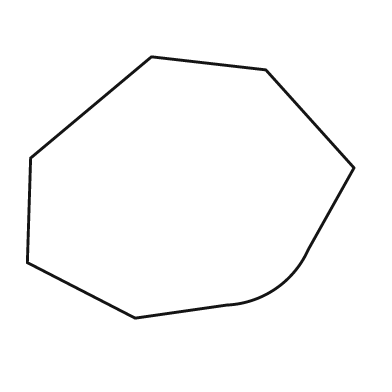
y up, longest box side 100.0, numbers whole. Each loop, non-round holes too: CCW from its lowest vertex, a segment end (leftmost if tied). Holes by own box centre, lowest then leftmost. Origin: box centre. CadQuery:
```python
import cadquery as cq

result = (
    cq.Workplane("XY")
    .moveTo(-17.0, -40.0)
    .lineTo(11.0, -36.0)
    .threePointArc((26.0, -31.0), (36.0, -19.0))
    .lineTo(50.0, 6.0)
    .lineTo(23.0, 36.0)
    .lineTo(-12.0, 40.0)
    .lineTo(-49.0, 9.0)
    .lineTo(-50.0, -23.0)
    .close()
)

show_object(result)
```